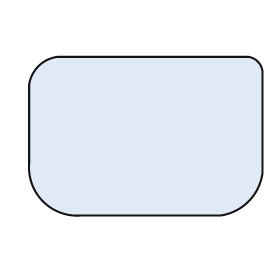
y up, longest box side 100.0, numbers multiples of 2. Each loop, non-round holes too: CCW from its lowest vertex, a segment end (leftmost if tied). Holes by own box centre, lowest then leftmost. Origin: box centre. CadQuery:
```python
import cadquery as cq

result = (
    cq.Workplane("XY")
    .moveTo(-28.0, -34.0)
    .lineTo(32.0, -34.0)
    .threePointArc((44.0, -28.0), (50.0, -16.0))
    .lineTo(50.0, 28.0)
    .threePointArc((48.0, 32.0), (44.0, 34.0))
    .lineTo(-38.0, 34.0)
    .threePointArc((-46.0, 30.0), (-50.0, 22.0))
    .lineTo(-50.0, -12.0)
    .threePointArc((-44.0, -28.0), (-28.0, -34.0))
    .close()
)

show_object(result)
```